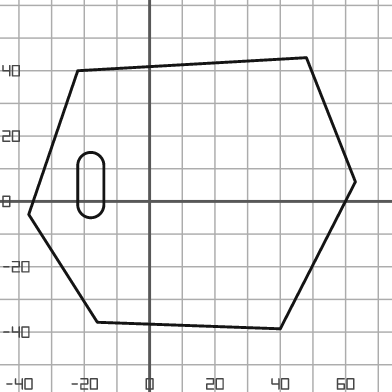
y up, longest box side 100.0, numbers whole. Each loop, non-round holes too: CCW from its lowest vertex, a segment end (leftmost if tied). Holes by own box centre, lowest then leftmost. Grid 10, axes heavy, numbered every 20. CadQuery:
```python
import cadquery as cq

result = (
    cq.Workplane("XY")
    .moveTo(40.0, -39.0)
    .lineTo(63.0, 6.0)
    .lineTo(48.0, 44.0)
    .lineTo(-22.0, 40.0)
    .lineTo(-37.0, -4.0)
    .lineTo(-16.0, -37.0)
    .close()
    .moveTo(-22.0, -1.0)
    .threePointArc((-18.0, -5.0), (-14.0, -1.0))
    .lineTo(-14.0, 11.0)
    .threePointArc((-18.0, 15.0), (-22.0, 11.0))
    .close()
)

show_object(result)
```